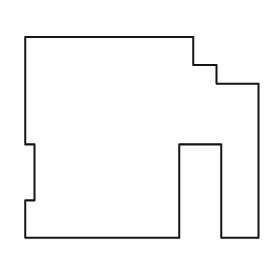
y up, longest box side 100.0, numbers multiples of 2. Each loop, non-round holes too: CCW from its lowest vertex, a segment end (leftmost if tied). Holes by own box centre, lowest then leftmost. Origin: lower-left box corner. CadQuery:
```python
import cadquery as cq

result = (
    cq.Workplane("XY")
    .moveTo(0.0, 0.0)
    .lineTo(66.0, 0.0)
    .lineTo(66.0, 40.0)
    .lineTo(84.0, 40.0)
    .lineTo(84.0, 0.0)
    .lineTo(100.0, 0.0)
    .lineTo(100.0, 66.0)
    .lineTo(82.0, 66.0)
    .lineTo(82.0, 74.0)
    .lineTo(72.0, 74.0)
    .lineTo(72.0, 86.0)
    .lineTo(0.0, 86.0)
    .lineTo(0.0, 40.0)
    .lineTo(4.0, 40.0)
    .lineTo(4.0, 16.0)
    .lineTo(0.0, 16.0)
    .close()
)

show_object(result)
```